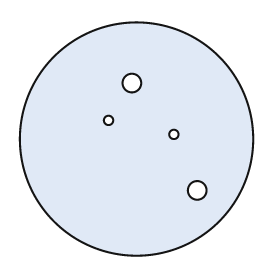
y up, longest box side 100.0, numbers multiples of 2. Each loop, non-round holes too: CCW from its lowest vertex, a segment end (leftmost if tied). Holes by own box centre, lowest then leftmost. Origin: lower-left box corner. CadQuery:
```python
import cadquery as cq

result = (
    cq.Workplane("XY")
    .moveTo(50.0, 50.0)
    .circle(50.0)
    .moveTo(76.0, 28.0)
    .circle(4.0)
    .moveTo(66.0, 52.0)
    .circle(2.0)
    .moveTo(38.0, 58.0)
    .circle(2.0)
    .moveTo(48.0, 74.0)
    .circle(4.0)
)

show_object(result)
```